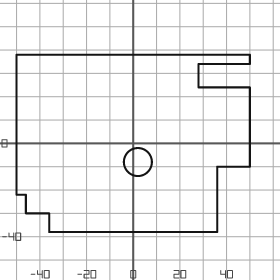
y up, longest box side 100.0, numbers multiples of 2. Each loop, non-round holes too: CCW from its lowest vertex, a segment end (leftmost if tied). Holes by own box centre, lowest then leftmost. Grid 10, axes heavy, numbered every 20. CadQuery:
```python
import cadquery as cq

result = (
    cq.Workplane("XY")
    .moveTo(-36.0, -38.0)
    .lineTo(36.0, -38.0)
    .lineTo(36.0, -10.0)
    .lineTo(50.0, -10.0)
    .lineTo(50.0, 24.0)
    .lineTo(28.0, 24.0)
    .lineTo(28.0, 34.0)
    .lineTo(50.0, 34.0)
    .lineTo(50.0, 38.0)
    .lineTo(-50.0, 38.0)
    .lineTo(-50.0, -22.0)
    .lineTo(-46.0, -22.0)
    .lineTo(-46.0, -30.0)
    .lineTo(-36.0, -30.0)
    .close()
    .moveTo(2.0, -8.0)
    .circle(6.0)
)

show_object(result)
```